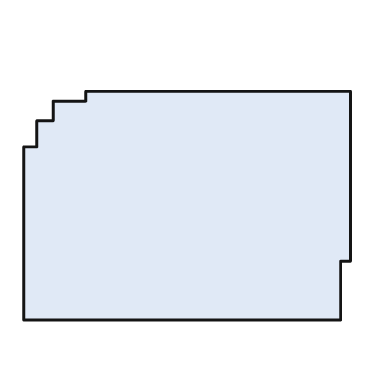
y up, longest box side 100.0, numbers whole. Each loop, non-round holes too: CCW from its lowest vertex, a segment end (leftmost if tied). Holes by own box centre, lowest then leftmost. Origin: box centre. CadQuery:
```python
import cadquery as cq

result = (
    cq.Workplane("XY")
    .moveTo(-50.0, -35.0)
    .lineTo(47.0, -35.0)
    .lineTo(47.0, -17.0)
    .lineTo(50.0, -17.0)
    .lineTo(50.0, 35.0)
    .lineTo(-31.0, 35.0)
    .lineTo(-31.0, 32.0)
    .lineTo(-41.0, 32.0)
    .lineTo(-41.0, 26.0)
    .lineTo(-46.0, 26.0)
    .lineTo(-46.0, 18.0)
    .lineTo(-50.0, 18.0)
    .close()
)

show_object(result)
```